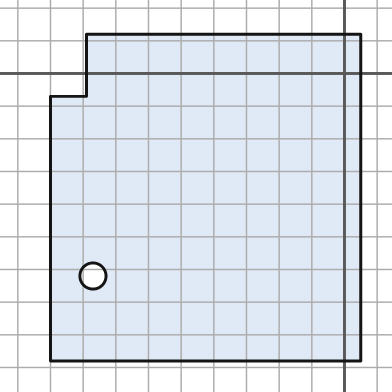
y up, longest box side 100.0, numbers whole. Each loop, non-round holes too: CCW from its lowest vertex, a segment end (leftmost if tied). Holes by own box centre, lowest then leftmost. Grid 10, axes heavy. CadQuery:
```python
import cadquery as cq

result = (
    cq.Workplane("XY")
    .moveTo(-90.0, -88.0)
    .lineTo(5.0, -88.0)
    .lineTo(5.0, 12.0)
    .lineTo(-79.0, 12.0)
    .lineTo(-79.0, -7.0)
    .lineTo(-90.0, -7.0)
    .close()
    .moveTo(-77.0, -62.0)
    .circle(4.0)
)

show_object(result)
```